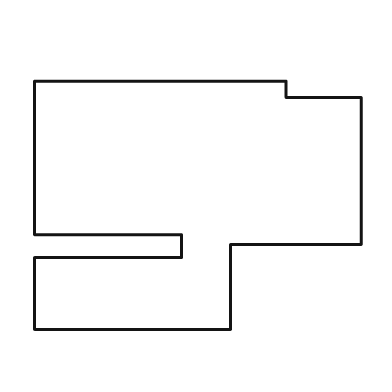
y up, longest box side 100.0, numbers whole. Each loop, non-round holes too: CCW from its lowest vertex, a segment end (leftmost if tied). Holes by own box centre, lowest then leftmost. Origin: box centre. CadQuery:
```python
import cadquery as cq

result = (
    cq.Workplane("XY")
    .moveTo(-50.0, -38.0)
    .lineTo(10.0, -38.0)
    .lineTo(10.0, -12.0)
    .lineTo(50.0, -12.0)
    .lineTo(50.0, 33.0)
    .lineTo(27.0, 33.0)
    .lineTo(27.0, 38.0)
    .lineTo(-50.0, 38.0)
    .lineTo(-50.0, -9.0)
    .lineTo(-5.0, -9.0)
    .lineTo(-5.0, -16.0)
    .lineTo(-50.0, -16.0)
    .close()
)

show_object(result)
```